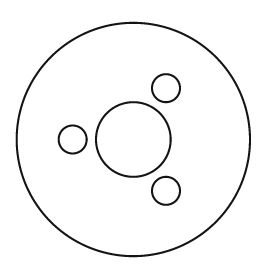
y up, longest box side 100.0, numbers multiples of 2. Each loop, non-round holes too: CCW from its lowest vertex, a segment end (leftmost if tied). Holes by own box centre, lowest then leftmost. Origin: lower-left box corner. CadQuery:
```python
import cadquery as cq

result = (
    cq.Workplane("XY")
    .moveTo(50.0, 50.0)
    .circle(50.0)
    .moveTo(64.0, 28.0)
    .circle(6.0)
    .moveTo(24.0, 50.0)
    .circle(6.0)
    .moveTo(50.0, 50.0)
    .circle(16.0)
    .moveTo(64.0, 72.0)
    .circle(6.0)
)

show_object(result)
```